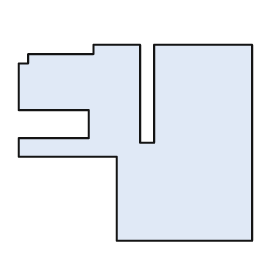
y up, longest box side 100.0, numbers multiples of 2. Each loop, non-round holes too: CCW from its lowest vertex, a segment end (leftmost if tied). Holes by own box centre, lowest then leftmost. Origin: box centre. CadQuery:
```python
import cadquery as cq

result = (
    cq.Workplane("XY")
    .moveTo(-8.0, -42.0)
    .lineTo(50.0, -42.0)
    .lineTo(50.0, 42.0)
    .lineTo(8.0, 42.0)
    .lineTo(8.0, 0.0)
    .lineTo(2.0, 0.0)
    .lineTo(2.0, 42.0)
    .lineTo(-18.0, 42.0)
    .lineTo(-18.0, 38.0)
    .lineTo(-46.0, 38.0)
    .lineTo(-46.0, 34.0)
    .lineTo(-50.0, 34.0)
    .lineTo(-50.0, 14.0)
    .lineTo(-20.0, 14.0)
    .lineTo(-20.0, 2.0)
    .lineTo(-50.0, 2.0)
    .lineTo(-50.0, -6.0)
    .lineTo(-8.0, -6.0)
    .close()
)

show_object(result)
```